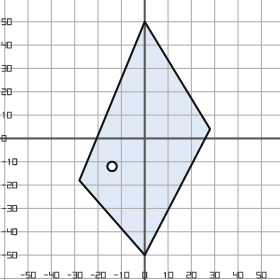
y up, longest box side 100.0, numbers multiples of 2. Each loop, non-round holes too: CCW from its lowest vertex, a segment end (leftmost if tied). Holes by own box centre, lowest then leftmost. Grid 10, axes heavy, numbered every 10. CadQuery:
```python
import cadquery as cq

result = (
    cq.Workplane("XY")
    .moveTo(0.0, -50.0)
    .lineTo(28.0, 4.0)
    .lineTo(0.0, 50.0)
    .lineTo(-28.0, -18.0)
    .close()
    .moveTo(-14.0, -12.0)
    .circle(2.0)
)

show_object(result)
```